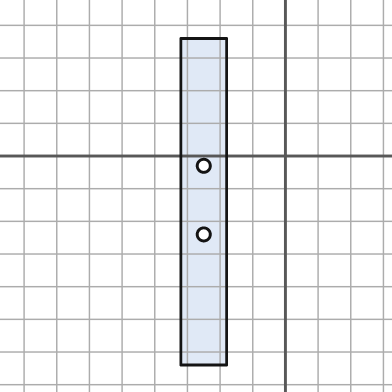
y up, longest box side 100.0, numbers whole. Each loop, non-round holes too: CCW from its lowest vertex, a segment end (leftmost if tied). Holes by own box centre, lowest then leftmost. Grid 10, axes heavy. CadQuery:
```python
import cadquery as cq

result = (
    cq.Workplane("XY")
    .moveTo(-32.0, -64.0)
    .lineTo(-18.0, -64.0)
    .lineTo(-18.0, 36.0)
    .lineTo(-32.0, 36.0)
    .close()
    .moveTo(-25.0, -24.0)
    .circle(2.0)
    .moveTo(-25.0, -3.0)
    .circle(2.0)
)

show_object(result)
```